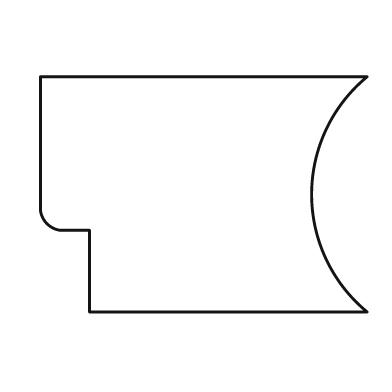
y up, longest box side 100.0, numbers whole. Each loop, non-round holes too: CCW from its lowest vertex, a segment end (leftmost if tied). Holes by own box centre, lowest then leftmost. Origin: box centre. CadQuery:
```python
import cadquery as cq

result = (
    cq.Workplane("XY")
    .moveTo(-35.0, -36.0)
    .lineTo(50.0, -36.0)
    .threePointArc((33.0, 0.0), (50.0, 36.0))
    .lineTo(-50.0, 36.0)
    .lineTo(-50.0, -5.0)
    .threePointArc((-48.0, -9.0), (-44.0, -11.0))
    .lineTo(-35.0, -11.0)
    .close()
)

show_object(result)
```